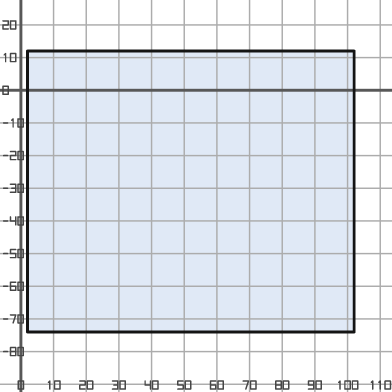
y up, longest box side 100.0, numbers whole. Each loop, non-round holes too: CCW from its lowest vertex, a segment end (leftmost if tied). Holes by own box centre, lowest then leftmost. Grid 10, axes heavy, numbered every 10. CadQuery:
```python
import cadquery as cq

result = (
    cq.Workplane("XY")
    .moveTo(2.0, -74.0)
    .lineTo(102.0, -74.0)
    .lineTo(102.0, 12.0)
    .lineTo(2.0, 12.0)
    .close()
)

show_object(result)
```